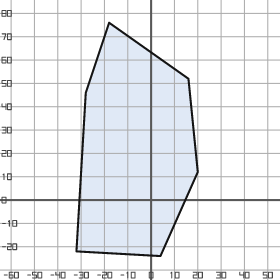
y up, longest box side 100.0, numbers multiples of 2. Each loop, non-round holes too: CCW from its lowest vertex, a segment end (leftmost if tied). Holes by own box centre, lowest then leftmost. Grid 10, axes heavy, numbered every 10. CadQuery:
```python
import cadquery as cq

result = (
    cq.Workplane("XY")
    .moveTo(4.0, -24.0)
    .lineTo(20.0, 12.0)
    .lineTo(16.0, 52.0)
    .lineTo(-18.0, 76.0)
    .lineTo(-28.0, 46.0)
    .lineTo(-32.0, -22.0)
    .close()
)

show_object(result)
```